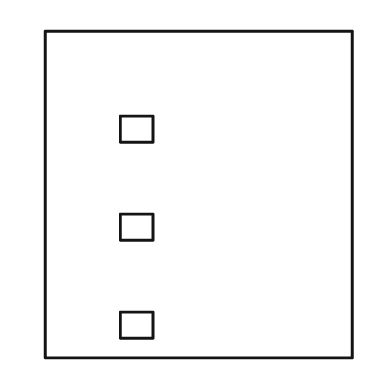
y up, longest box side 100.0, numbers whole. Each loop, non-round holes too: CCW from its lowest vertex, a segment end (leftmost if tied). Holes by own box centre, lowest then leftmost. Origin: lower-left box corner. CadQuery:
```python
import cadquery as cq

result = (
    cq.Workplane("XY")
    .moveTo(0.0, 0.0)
    .lineTo(94.0, 0.0)
    .lineTo(94.0, 100.0)
    .lineTo(0.0, 100.0)
    .close()
    .moveTo(23.0, 6.0)
    .lineTo(33.0, 6.0)
    .lineTo(33.0, 14.0)
    .lineTo(23.0, 14.0)
    .close()
    .moveTo(23.0, 36.0)
    .lineTo(33.0, 36.0)
    .lineTo(33.0, 44.0)
    .lineTo(23.0, 44.0)
    .close()
    .moveTo(23.0, 66.0)
    .lineTo(33.0, 66.0)
    .lineTo(33.0, 74.0)
    .lineTo(23.0, 74.0)
    .close()
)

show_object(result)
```